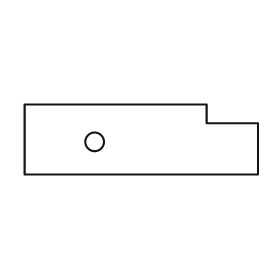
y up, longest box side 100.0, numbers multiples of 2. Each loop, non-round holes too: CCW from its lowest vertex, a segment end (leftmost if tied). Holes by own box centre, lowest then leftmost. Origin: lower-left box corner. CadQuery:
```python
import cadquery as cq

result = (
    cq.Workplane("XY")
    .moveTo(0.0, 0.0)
    .lineTo(100.0, 0.0)
    .lineTo(100.0, 22.0)
    .lineTo(78.0, 22.0)
    .lineTo(78.0, 30.0)
    .lineTo(0.0, 30.0)
    .close()
    .moveTo(30.0, 14.0)
    .circle(4.0)
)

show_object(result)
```